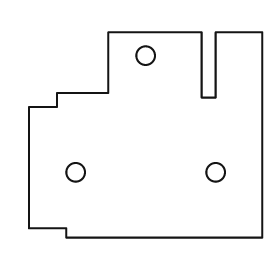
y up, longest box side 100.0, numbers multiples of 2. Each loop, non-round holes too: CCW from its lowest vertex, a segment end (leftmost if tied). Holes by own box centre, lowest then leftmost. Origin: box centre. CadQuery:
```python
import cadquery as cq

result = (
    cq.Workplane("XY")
    .moveTo(-34.0, -44.0)
    .lineTo(50.0, -44.0)
    .lineTo(50.0, 44.0)
    .lineTo(30.0, 44.0)
    .lineTo(30.0, 16.0)
    .lineTo(24.0, 16.0)
    .lineTo(24.0, 44.0)
    .lineTo(-16.0, 44.0)
    .lineTo(-16.0, 18.0)
    .lineTo(-38.0, 18.0)
    .lineTo(-38.0, 12.0)
    .lineTo(-50.0, 12.0)
    .lineTo(-50.0, -40.0)
    .lineTo(-34.0, -40.0)
    .close()
    .moveTo(-30.0, -16.0)
    .circle(4.0)
    .moveTo(30.0, -16.0)
    .circle(4.0)
    .moveTo(0.0, 34.0)
    .circle(4.0)
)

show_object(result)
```